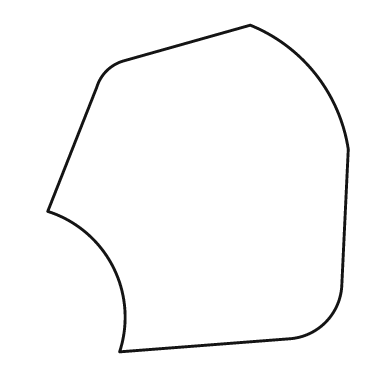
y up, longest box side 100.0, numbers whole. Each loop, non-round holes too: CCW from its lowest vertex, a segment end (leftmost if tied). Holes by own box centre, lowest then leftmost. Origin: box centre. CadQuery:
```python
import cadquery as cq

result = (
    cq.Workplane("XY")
    .moveTo(-24.0, -50.0)
    .lineTo(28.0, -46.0)
    .threePointArc((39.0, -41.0), (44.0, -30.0))
    .lineTo(46.0, 12.0)
    .threePointArc((36.0, 35.0), (16.0, 50.0))
    .lineTo(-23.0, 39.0)
    .threePointArc((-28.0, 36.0), (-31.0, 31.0))
    .lineTo(-46.0, -7.0)
    .threePointArc((-26.0, -24.0), (-24.0, -50.0))
    .close()
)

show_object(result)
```